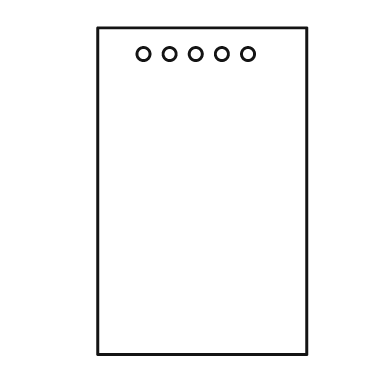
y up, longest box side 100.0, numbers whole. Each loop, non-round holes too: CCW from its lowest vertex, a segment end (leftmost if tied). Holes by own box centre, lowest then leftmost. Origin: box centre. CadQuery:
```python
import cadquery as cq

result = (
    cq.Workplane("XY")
    .moveTo(-32.0, -50.0)
    .lineTo(32.0, -50.0)
    .lineTo(32.0, 50.0)
    .lineTo(-32.0, 50.0)
    .close()
    .moveTo(-18.0, 42.0)
    .circle(2.0)
    .moveTo(-10.0, 42.0)
    .circle(2.0)
    .moveTo(-2.0, 42.0)
    .circle(2.0)
    .moveTo(6.0, 42.0)
    .circle(2.0)
    .moveTo(14.0, 42.0)
    .circle(2.0)
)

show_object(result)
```